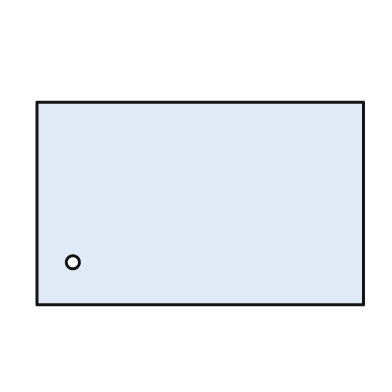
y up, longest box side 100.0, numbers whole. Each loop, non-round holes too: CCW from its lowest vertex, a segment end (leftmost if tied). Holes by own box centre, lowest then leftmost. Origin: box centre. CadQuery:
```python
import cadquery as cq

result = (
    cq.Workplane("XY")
    .moveTo(-50.0, -31.0)
    .lineTo(50.0, -31.0)
    .lineTo(50.0, 31.0)
    .lineTo(-50.0, 31.0)
    .close()
    .moveTo(-39.0, -18.0)
    .circle(2.0)
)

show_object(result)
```